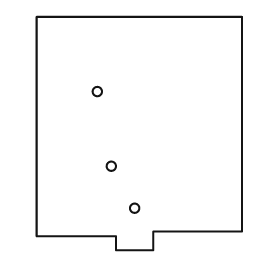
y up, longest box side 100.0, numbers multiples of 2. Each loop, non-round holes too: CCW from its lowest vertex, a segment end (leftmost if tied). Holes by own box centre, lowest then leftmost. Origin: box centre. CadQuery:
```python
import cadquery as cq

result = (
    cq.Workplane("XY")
    .moveTo(-10.0, -50.0)
    .lineTo(6.0, -50.0)
    .lineTo(6.0, -42.0)
    .lineTo(44.0, -42.0)
    .lineTo(44.0, 50.0)
    .lineTo(-44.0, 50.0)
    .lineTo(-44.0, -44.0)
    .lineTo(-10.0, -44.0)
    .close()
    .moveTo(-2.0, -32.0)
    .circle(2.0)
    .moveTo(-12.0, -14.0)
    .circle(2.0)
    .moveTo(-18.0, 18.0)
    .circle(2.0)
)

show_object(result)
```